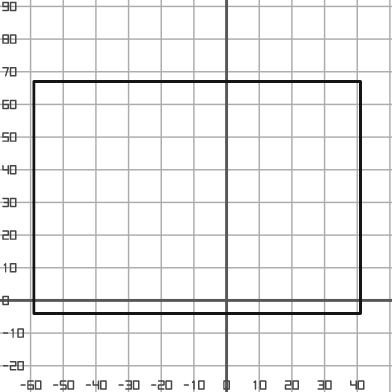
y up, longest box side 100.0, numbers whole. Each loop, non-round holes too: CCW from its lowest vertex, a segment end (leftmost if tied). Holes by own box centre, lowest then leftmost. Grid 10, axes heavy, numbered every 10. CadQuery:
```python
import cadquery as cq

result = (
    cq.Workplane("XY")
    .moveTo(-59.0, -4.0)
    .lineTo(41.0, -4.0)
    .lineTo(41.0, 67.0)
    .lineTo(-59.0, 67.0)
    .close()
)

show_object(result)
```